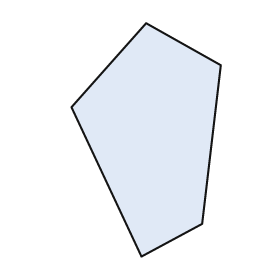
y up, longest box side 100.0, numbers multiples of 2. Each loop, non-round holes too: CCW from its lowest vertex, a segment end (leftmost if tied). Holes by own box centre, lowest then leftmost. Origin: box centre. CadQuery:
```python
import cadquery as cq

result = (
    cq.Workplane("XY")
    .moveTo(-2.0, -50.0)
    .lineTo(24.0, -36.0)
    .lineTo(32.0, 32.0)
    .lineTo(0.0, 50.0)
    .lineTo(-32.0, 14.0)
    .close()
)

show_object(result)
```